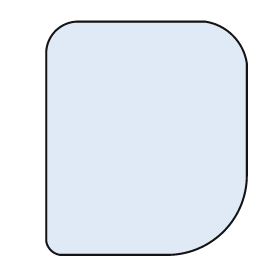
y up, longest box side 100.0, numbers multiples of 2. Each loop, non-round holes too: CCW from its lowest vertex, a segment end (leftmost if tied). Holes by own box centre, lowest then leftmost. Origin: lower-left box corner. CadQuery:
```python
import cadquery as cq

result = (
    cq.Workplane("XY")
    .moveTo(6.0, 0.0)
    .lineTo(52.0, 0.0)
    .threePointArc((76.0, 10.0), (86.0, 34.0))
    .lineTo(86.0, 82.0)
    .threePointArc((80.0, 94.0), (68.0, 100.0))
    .lineTo(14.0, 100.0)
    .threePointArc((4.0, 96.0), (0.0, 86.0))
    .lineTo(0.0, 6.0)
    .threePointArc((2.0, 2.0), (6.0, 0.0))
    .close()
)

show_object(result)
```